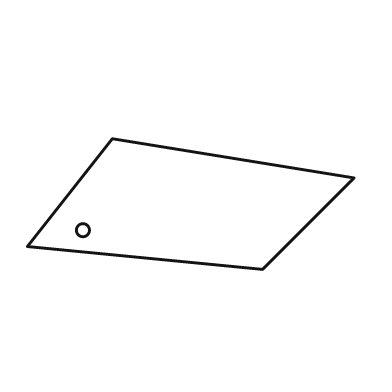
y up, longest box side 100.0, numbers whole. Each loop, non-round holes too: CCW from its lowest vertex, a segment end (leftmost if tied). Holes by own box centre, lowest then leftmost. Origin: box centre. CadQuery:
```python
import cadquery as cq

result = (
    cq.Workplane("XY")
    .moveTo(22.0, -20.0)
    .lineTo(50.0, 8.0)
    .lineTo(-24.0, 20.0)
    .lineTo(-50.0, -13.0)
    .close()
    .moveTo(-33.0, -8.0)
    .circle(2.0)
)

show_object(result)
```